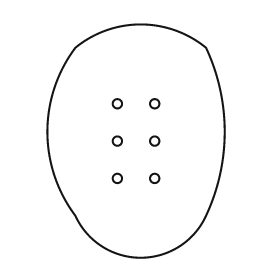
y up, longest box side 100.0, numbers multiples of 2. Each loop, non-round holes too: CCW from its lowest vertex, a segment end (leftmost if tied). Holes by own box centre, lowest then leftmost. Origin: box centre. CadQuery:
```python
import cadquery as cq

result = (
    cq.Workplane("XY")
    .moveTo(-26.0, -32.0)
    .threePointArc((2.0, -50.0), (30.0, -32.0))
    .threePointArc((38.0, 4.0), (30.0, 40.0))
    .threePointArc((2.0, 50.0), (-26.0, 40.0))
    .threePointArc((-38.0, 4.0), (-26.0, -32.0))
    .close()
    .moveTo(-8.0, -16.0)
    .circle(2.0)
    .moveTo(8.0, -16.0)
    .circle(2.0)
    .moveTo(-8.0, 0.0)
    .circle(2.0)
    .moveTo(8.0, 0.0)
    .circle(2.0)
    .moveTo(-8.0, 16.0)
    .circle(2.0)
    .moveTo(8.0, 16.0)
    .circle(2.0)
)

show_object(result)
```